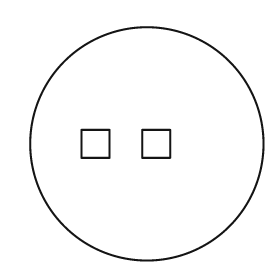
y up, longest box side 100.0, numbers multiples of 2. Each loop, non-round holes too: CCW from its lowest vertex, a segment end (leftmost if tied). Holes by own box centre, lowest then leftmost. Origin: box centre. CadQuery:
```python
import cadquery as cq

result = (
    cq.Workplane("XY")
    .moveTo(0.0, 0.0)
    .circle(50.0)
    .moveTo(-28.0, -6.0)
    .lineTo(-16.0, -6.0)
    .lineTo(-16.0, 6.0)
    .lineTo(-28.0, 6.0)
    .close()
    .moveTo(-2.0, -6.0)
    .lineTo(10.0, -6.0)
    .lineTo(10.0, 6.0)
    .lineTo(-2.0, 6.0)
    .close()
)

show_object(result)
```